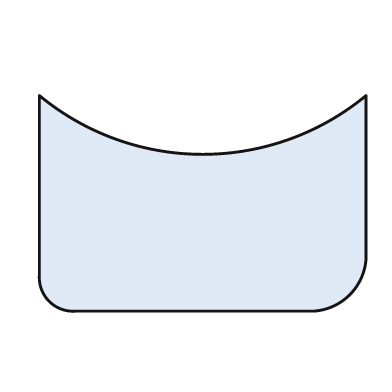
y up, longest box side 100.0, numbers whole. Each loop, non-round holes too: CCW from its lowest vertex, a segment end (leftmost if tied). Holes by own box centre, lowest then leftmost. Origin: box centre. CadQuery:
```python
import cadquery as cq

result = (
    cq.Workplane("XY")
    .moveTo(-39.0, -33.0)
    .lineTo(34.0, -33.0)
    .threePointArc((45.0, -28.0), (50.0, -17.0))
    .lineTo(50.0, 33.0)
    .threePointArc((0.0, 15.0), (-50.0, 33.0))
    .lineTo(-50.0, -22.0)
    .threePointArc((-47.0, -30.0), (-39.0, -33.0))
    .close()
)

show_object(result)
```